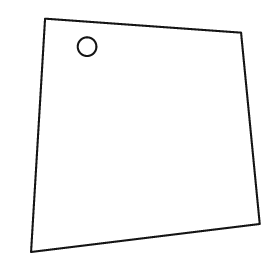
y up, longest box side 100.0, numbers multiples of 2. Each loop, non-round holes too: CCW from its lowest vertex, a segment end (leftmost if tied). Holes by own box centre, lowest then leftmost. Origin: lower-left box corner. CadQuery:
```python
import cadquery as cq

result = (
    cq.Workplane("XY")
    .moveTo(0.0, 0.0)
    .lineTo(98.0, 12.0)
    .lineTo(90.0, 94.0)
    .lineTo(6.0, 100.0)
    .close()
    .moveTo(24.0, 88.0)
    .circle(4.0)
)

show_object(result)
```